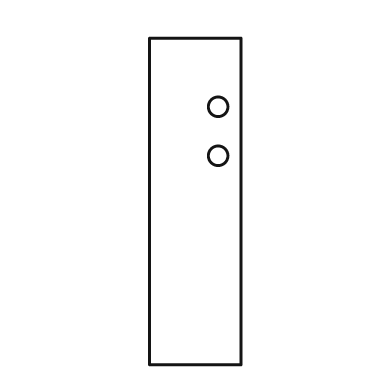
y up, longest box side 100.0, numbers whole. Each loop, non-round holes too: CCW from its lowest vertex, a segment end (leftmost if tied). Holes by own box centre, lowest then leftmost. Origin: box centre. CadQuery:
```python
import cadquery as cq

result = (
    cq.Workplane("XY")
    .moveTo(-14.0, -50.0)
    .lineTo(14.0, -50.0)
    .lineTo(14.0, 50.0)
    .lineTo(-14.0, 50.0)
    .close()
    .moveTo(7.0, 14.0)
    .circle(3.0)
    .moveTo(7.0, 29.0)
    .circle(3.0)
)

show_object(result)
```